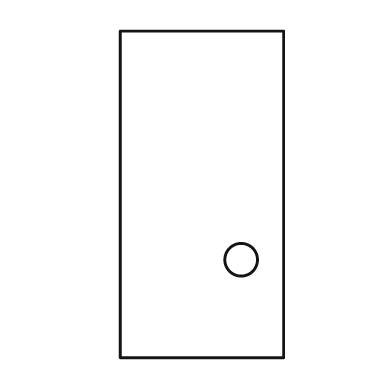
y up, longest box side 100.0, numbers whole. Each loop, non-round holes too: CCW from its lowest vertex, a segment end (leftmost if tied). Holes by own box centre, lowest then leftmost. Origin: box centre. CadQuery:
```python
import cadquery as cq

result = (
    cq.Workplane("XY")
    .moveTo(-25.0, -50.0)
    .lineTo(25.0, -50.0)
    .lineTo(25.0, 50.0)
    .lineTo(-25.0, 50.0)
    .close()
    .moveTo(12.0, -20.0)
    .circle(5.0)
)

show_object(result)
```